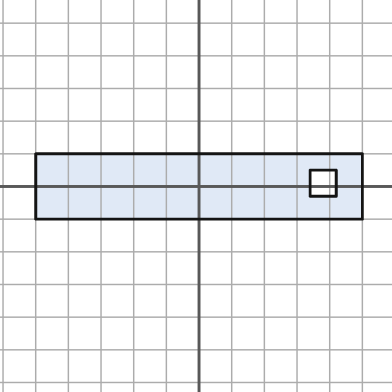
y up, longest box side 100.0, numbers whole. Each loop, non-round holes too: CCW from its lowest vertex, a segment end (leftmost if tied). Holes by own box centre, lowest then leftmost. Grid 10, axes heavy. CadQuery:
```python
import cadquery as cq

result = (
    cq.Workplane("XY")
    .moveTo(-50.0, -10.0)
    .lineTo(50.0, -10.0)
    .lineTo(50.0, 10.0)
    .lineTo(-50.0, 10.0)
    .close()
    .moveTo(34.0, -3.0)
    .lineTo(42.0, -3.0)
    .lineTo(42.0, 5.0)
    .lineTo(34.0, 5.0)
    .close()
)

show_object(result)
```